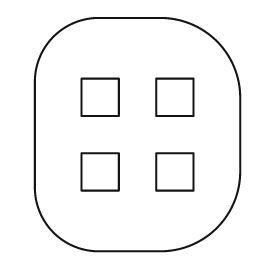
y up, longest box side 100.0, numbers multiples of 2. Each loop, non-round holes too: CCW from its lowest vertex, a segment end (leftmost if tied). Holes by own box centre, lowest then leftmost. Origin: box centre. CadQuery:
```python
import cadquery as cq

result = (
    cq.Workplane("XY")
    .moveTo(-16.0, -50.0)
    .lineTo(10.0, -50.0)
    .threePointArc((34.0, -40.0), (44.0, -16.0))
    .lineTo(44.0, 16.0)
    .threePointArc((34.0, 40.0), (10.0, 50.0))
    .lineTo(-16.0, 50.0)
    .threePointArc((-36.0, 42.0), (-44.0, 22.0))
    .lineTo(-44.0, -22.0)
    .threePointArc((-36.0, -42.0), (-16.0, -50.0))
    .close()
    .moveTo(-24.0, -24.0)
    .lineTo(-8.0, -24.0)
    .lineTo(-8.0, -8.0)
    .lineTo(-24.0, -8.0)
    .close()
    .moveTo(8.0, -24.0)
    .lineTo(24.0, -24.0)
    .lineTo(24.0, -8.0)
    .lineTo(8.0, -8.0)
    .close()
    .moveTo(-24.0, 8.0)
    .lineTo(-8.0, 8.0)
    .lineTo(-8.0, 24.0)
    .lineTo(-24.0, 24.0)
    .close()
    .moveTo(8.0, 8.0)
    .lineTo(24.0, 8.0)
    .lineTo(24.0, 24.0)
    .lineTo(8.0, 24.0)
    .close()
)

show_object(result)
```